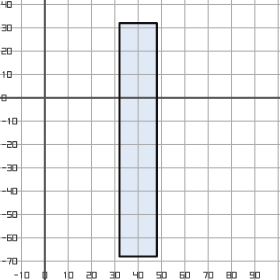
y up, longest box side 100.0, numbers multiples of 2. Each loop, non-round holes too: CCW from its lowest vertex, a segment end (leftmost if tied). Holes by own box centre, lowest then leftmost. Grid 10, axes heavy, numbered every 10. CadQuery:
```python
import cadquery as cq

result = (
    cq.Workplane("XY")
    .moveTo(32.0, -68.0)
    .lineTo(48.0, -68.0)
    .lineTo(48.0, 32.0)
    .lineTo(32.0, 32.0)
    .close()
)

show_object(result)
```